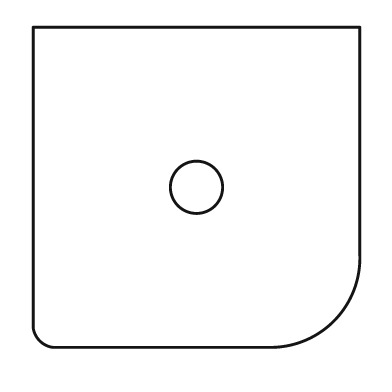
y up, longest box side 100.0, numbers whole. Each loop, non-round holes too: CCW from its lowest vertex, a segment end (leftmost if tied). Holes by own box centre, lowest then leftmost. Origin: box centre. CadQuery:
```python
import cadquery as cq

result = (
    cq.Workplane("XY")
    .moveTo(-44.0, -49.0)
    .lineTo(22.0, -49.0)
    .threePointArc((42.0, -41.0), (50.0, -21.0))
    .lineTo(50.0, 49.0)
    .lineTo(-50.0, 49.0)
    .lineTo(-50.0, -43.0)
    .threePointArc((-48.0, -47.0), (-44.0, -49.0))
    .close()
    .moveTo(0.0, 0.0)
    .circle(8.0)
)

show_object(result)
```